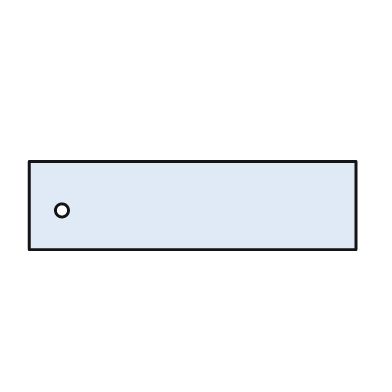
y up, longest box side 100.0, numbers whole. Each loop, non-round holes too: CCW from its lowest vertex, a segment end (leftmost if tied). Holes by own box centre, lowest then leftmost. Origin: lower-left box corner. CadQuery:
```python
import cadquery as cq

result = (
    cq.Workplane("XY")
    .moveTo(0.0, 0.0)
    .lineTo(100.0, 0.0)
    .lineTo(100.0, 27.0)
    .lineTo(0.0, 27.0)
    .close()
    .moveTo(10.0, 12.0)
    .circle(2.0)
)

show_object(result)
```